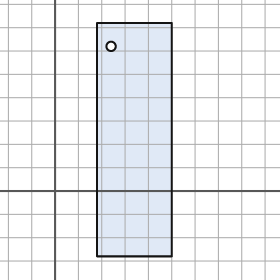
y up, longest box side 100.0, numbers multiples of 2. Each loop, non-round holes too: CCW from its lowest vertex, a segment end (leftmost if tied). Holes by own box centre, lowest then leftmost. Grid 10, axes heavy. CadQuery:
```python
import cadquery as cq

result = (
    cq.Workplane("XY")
    .moveTo(18.0, -28.0)
    .lineTo(50.0, -28.0)
    .lineTo(50.0, 72.0)
    .lineTo(18.0, 72.0)
    .close()
    .moveTo(24.0, 62.0)
    .circle(2.0)
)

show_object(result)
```